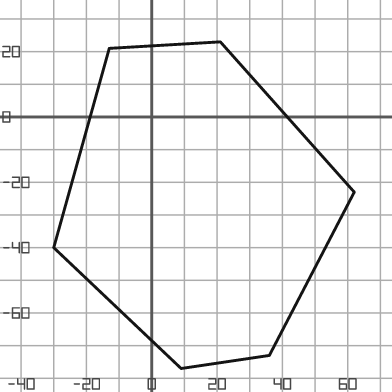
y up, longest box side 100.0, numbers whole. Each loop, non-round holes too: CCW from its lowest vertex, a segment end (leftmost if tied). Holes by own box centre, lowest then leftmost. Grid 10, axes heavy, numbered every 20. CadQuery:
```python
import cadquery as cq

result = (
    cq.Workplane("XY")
    .moveTo(9.0, -77.0)
    .lineTo(36.0, -73.0)
    .lineTo(62.0, -23.0)
    .lineTo(21.0, 23.0)
    .lineTo(-13.0, 21.0)
    .lineTo(-30.0, -40.0)
    .close()
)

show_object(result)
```